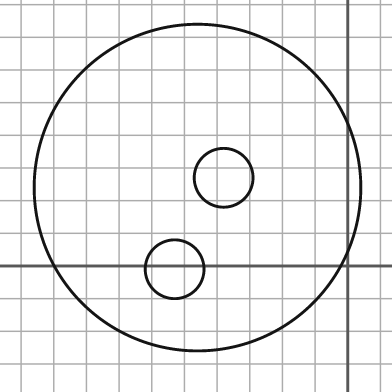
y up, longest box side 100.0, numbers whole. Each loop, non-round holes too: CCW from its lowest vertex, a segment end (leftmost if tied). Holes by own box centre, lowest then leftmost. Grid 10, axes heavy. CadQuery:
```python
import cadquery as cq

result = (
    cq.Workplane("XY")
    .moveTo(-46.0, 24.0)
    .circle(50.0)
    .moveTo(-53.0, -1.0)
    .circle(9.0)
    .moveTo(-38.0, 27.0)
    .circle(9.0)
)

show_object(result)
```